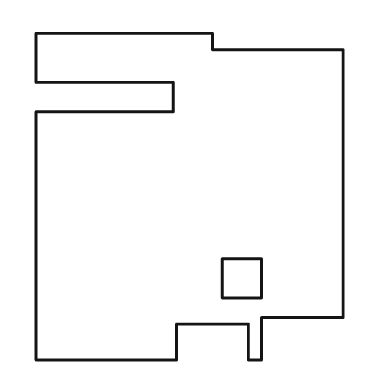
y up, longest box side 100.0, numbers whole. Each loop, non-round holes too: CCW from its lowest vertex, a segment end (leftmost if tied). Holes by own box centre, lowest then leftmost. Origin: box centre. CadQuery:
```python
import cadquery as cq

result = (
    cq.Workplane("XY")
    .moveTo(-47.0, -50.0)
    .lineTo(-4.0, -50.0)
    .lineTo(-4.0, -39.0)
    .lineTo(18.0, -39.0)
    .lineTo(18.0, -50.0)
    .lineTo(22.0, -50.0)
    .lineTo(22.0, -37.0)
    .lineTo(47.0, -37.0)
    .lineTo(47.0, 45.0)
    .lineTo(7.0, 45.0)
    .lineTo(7.0, 50.0)
    .lineTo(-47.0, 50.0)
    .lineTo(-47.0, 35.0)
    .lineTo(-5.0, 35.0)
    .lineTo(-5.0, 26.0)
    .lineTo(-47.0, 26.0)
    .close()
    .moveTo(10.0, -31.0)
    .lineTo(22.0, -31.0)
    .lineTo(22.0, -19.0)
    .lineTo(10.0, -19.0)
    .close()
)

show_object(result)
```